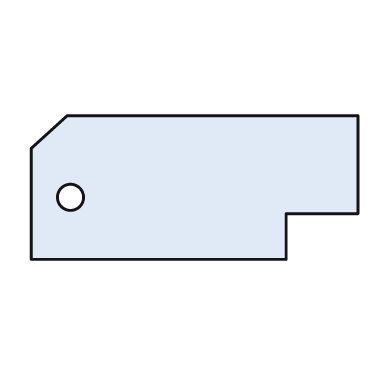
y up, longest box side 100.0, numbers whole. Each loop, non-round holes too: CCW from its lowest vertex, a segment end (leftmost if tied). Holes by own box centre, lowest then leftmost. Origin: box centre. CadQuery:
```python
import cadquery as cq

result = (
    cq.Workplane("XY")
    .moveTo(-50.0, -22.0)
    .lineTo(28.0, -22.0)
    .lineTo(28.0, -8.0)
    .lineTo(50.0, -8.0)
    .lineTo(50.0, 22.0)
    .lineTo(-39.0, 22.0)
    .lineTo(-50.0, 12.0)
    .close()
    .moveTo(-38.0, -3.0)
    .circle(4.0)
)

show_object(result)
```